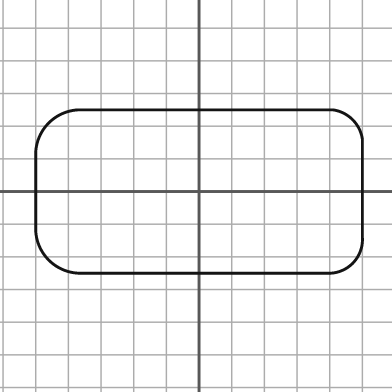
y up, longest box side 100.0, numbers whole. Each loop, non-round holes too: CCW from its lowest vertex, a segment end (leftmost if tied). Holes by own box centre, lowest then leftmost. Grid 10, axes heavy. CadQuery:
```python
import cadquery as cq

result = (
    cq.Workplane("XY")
    .moveTo(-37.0, -25.0)
    .lineTo(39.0, -25.0)
    .threePointArc((47.0, -22.0), (50.0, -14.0))
    .lineTo(50.0, 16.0)
    .threePointArc((47.0, 22.0), (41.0, 25.0))
    .lineTo(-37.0, 25.0)
    .threePointArc((-46.0, 21.0), (-50.0, 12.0))
    .lineTo(-50.0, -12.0)
    .threePointArc((-46.0, -21.0), (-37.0, -25.0))
    .close()
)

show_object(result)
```